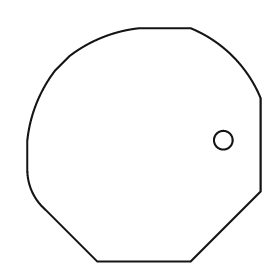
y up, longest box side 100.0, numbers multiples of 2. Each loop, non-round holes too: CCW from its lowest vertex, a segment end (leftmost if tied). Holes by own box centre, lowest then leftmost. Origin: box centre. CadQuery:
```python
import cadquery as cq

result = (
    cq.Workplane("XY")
    .moveTo(-20.0, -50.0)
    .lineTo(20.0, -50.0)
    .lineTo(50.0, -20.0)
    .lineTo(50.0, 20.0)
    .threePointArc((38.0, 38.0), (20.0, 50.0))
    .lineTo(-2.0, 50.0)
    .threePointArc((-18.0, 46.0), (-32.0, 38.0))
    .lineTo(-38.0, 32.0)
    .threePointArc((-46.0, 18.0), (-50.0, 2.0))
    .lineTo(-50.0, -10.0)
    .threePointArc((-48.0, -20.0), (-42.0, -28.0))
    .close()
    .moveTo(34.0, 2.0)
    .circle(4.0)
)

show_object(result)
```